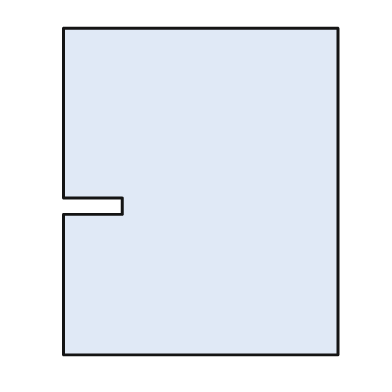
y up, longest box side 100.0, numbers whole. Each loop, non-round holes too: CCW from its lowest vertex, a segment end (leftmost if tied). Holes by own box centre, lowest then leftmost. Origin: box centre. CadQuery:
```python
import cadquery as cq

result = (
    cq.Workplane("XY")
    .moveTo(-42.0, -50.0)
    .lineTo(42.0, -50.0)
    .lineTo(42.0, 50.0)
    .lineTo(-42.0, 50.0)
    .lineTo(-42.0, -2.0)
    .lineTo(-24.0, -2.0)
    .lineTo(-24.0, -7.0)
    .lineTo(-42.0, -7.0)
    .close()
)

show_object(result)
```